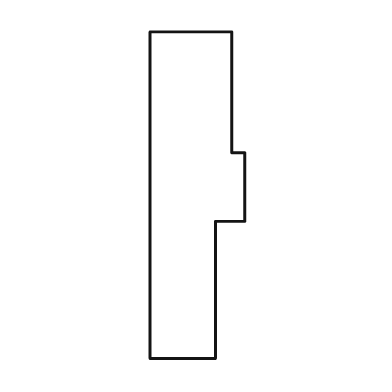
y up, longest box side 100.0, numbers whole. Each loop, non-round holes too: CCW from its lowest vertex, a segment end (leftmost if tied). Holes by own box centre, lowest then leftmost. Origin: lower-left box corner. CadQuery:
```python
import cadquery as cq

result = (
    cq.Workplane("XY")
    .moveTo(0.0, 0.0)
    .lineTo(20.0, 0.0)
    .lineTo(20.0, 42.0)
    .lineTo(29.0, 42.0)
    .lineTo(29.0, 63.0)
    .lineTo(25.0, 63.0)
    .lineTo(25.0, 100.0)
    .lineTo(0.0, 100.0)
    .close()
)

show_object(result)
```